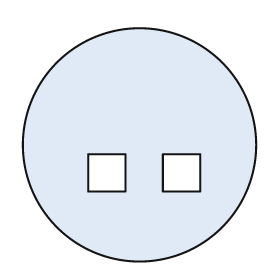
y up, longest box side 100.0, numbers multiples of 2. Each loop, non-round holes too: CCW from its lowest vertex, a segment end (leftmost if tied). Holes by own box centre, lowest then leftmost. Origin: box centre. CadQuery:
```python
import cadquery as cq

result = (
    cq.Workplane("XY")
    .moveTo(0.0, 0.0)
    .circle(50.0)
    .moveTo(-22.0, -20.0)
    .lineTo(-6.0, -20.0)
    .lineTo(-6.0, -4.0)
    .lineTo(-22.0, -4.0)
    .close()
    .moveTo(10.0, -20.0)
    .lineTo(26.0, -20.0)
    .lineTo(26.0, -4.0)
    .lineTo(10.0, -4.0)
    .close()
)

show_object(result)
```